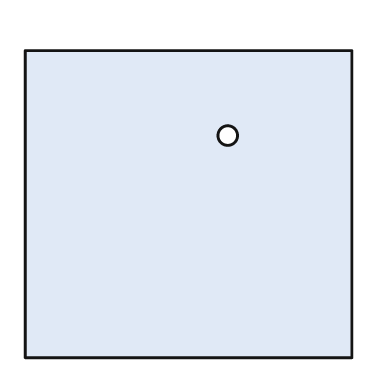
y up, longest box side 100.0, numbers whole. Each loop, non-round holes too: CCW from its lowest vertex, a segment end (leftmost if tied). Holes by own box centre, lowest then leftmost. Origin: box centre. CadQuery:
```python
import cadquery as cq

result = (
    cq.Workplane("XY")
    .moveTo(-50.0, -47.0)
    .lineTo(50.0, -47.0)
    .lineTo(50.0, 47.0)
    .lineTo(-50.0, 47.0)
    .close()
    .moveTo(12.0, 21.0)
    .circle(3.0)
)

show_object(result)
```